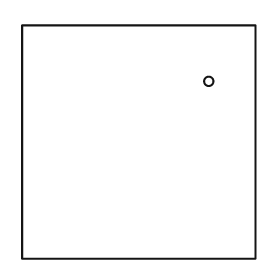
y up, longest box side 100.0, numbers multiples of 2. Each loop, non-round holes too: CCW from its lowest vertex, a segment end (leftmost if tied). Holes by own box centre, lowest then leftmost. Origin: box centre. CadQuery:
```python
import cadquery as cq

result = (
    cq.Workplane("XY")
    .moveTo(-50.0, -50.0)
    .lineTo(50.0, -50.0)
    .lineTo(50.0, 50.0)
    .lineTo(-50.0, 50.0)
    .close()
    .moveTo(30.0, 26.0)
    .circle(2.0)
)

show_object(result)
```